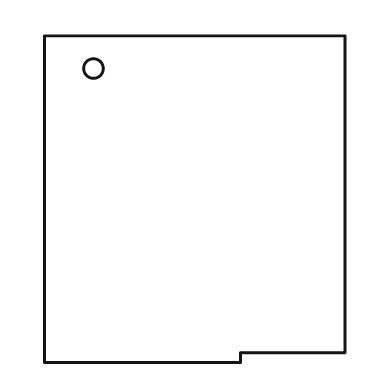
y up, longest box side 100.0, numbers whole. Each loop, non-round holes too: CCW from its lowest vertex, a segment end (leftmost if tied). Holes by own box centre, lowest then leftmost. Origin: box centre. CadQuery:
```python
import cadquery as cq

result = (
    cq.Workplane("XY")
    .moveTo(-46.0, -50.0)
    .lineTo(14.0, -50.0)
    .lineTo(14.0, -47.0)
    .lineTo(46.0, -47.0)
    .lineTo(46.0, 50.0)
    .lineTo(-46.0, 50.0)
    .close()
    .moveTo(-31.0, 40.0)
    .circle(3.0)
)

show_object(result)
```